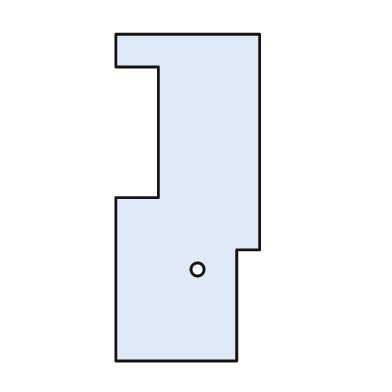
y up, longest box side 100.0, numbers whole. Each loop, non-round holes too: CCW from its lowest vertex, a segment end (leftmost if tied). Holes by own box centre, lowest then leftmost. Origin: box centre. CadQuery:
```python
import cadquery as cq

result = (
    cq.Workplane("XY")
    .moveTo(-22.0, -50.0)
    .lineTo(15.0, -50.0)
    .lineTo(15.0, -16.0)
    .lineTo(22.0, -16.0)
    .lineTo(22.0, 50.0)
    .lineTo(-22.0, 50.0)
    .lineTo(-22.0, 40.0)
    .lineTo(-9.0, 40.0)
    .lineTo(-9.0, 0.0)
    .lineTo(-22.0, 0.0)
    .close()
    .moveTo(3.0, -22.0)
    .circle(2.0)
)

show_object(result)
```